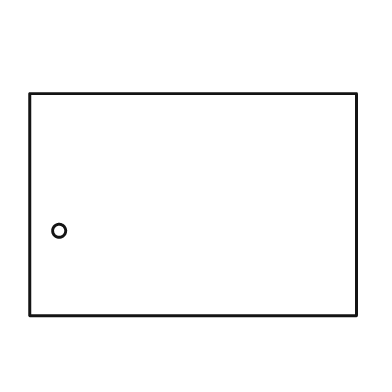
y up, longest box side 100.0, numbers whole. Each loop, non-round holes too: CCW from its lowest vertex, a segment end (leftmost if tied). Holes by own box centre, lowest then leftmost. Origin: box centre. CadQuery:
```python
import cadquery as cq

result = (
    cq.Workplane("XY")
    .moveTo(-50.0, -34.0)
    .lineTo(50.0, -34.0)
    .lineTo(50.0, 34.0)
    .lineTo(-50.0, 34.0)
    .close()
    .moveTo(-41.0, -8.0)
    .circle(2.0)
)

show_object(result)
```